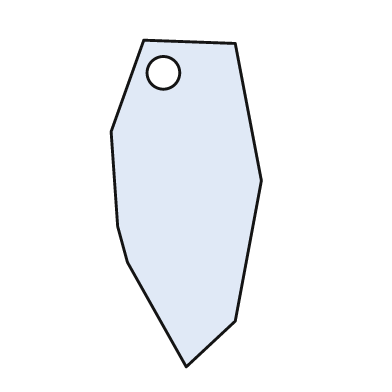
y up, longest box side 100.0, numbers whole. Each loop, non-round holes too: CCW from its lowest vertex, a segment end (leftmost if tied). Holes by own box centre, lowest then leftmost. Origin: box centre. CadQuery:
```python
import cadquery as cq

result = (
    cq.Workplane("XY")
    .moveTo(0.0, -50.0)
    .lineTo(15.0, -36.0)
    .lineTo(23.0, 7.0)
    .lineTo(15.0, 49.0)
    .lineTo(-13.0, 50.0)
    .lineTo(-23.0, 22.0)
    .lineTo(-21.0, -7.0)
    .lineTo(-18.0, -18.0)
    .close()
    .moveTo(-7.0, 40.0)
    .circle(5.0)
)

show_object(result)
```